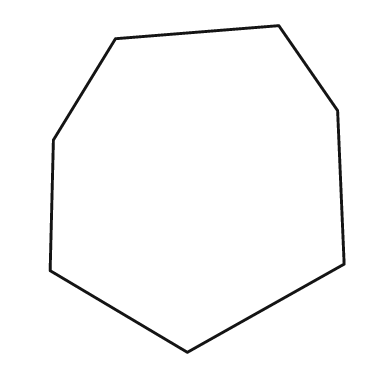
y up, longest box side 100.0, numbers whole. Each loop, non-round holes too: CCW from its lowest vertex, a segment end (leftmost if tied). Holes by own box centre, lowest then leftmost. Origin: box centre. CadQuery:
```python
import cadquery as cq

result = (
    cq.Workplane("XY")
    .moveTo(-3.0, -50.0)
    .lineTo(45.0, -23.0)
    .lineTo(43.0, 24.0)
    .lineTo(25.0, 50.0)
    .lineTo(-25.0, 46.0)
    .lineTo(-44.0, 15.0)
    .lineTo(-45.0, -25.0)
    .close()
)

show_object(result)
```